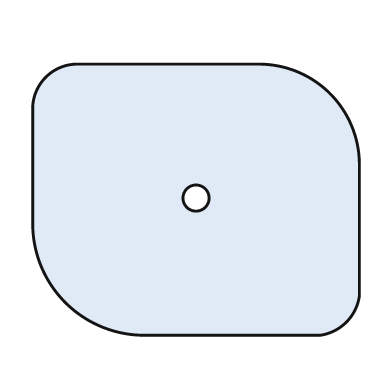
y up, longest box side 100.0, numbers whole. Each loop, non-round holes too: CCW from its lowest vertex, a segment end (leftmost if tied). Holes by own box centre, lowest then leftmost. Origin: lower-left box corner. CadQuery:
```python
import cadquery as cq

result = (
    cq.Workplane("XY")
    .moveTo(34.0, 0.0)
    .lineTo(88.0, 0.0)
    .threePointArc((96.0, 4.0), (100.0, 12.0))
    .lineTo(100.0, 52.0)
    .threePointArc((91.0, 74.0), (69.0, 83.0))
    .lineTo(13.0, 83.0)
    .threePointArc((4.0, 79.0), (0.0, 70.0))
    .lineTo(0.0, 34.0)
    .threePointArc((10.0, 10.0), (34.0, 0.0))
    .close()
    .moveTo(50.0, 42.0)
    .circle(4.0)
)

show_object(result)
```